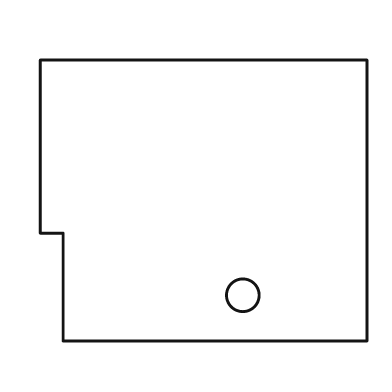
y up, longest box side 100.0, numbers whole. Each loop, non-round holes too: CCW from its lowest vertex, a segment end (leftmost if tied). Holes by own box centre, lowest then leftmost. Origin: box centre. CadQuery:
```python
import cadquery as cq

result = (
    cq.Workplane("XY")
    .moveTo(-43.0, -43.0)
    .lineTo(50.0, -43.0)
    .lineTo(50.0, 43.0)
    .lineTo(-50.0, 43.0)
    .lineTo(-50.0, -10.0)
    .lineTo(-43.0, -10.0)
    .close()
    .moveTo(12.0, -29.0)
    .circle(5.0)
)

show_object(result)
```